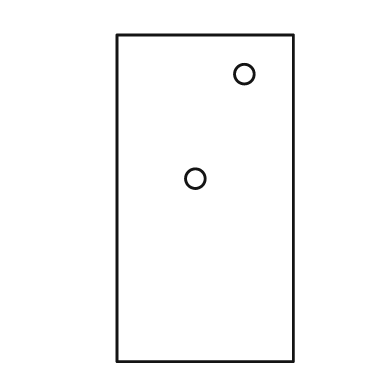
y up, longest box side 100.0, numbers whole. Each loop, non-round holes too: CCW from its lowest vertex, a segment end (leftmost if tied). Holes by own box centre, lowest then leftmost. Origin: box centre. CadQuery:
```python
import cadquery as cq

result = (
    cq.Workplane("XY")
    .moveTo(-27.0, -50.0)
    .lineTo(27.0, -50.0)
    .lineTo(27.0, 50.0)
    .lineTo(-27.0, 50.0)
    .close()
    .moveTo(-3.0, 6.0)
    .circle(3.0)
    .moveTo(12.0, 38.0)
    .circle(3.0)
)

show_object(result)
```